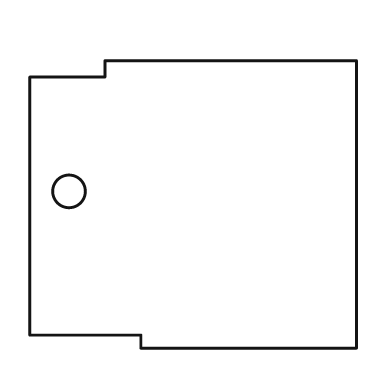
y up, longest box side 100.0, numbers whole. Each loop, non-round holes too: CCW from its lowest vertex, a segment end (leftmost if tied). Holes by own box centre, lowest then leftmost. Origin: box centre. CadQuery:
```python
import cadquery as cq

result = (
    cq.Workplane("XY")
    .moveTo(-16.0, -44.0)
    .lineTo(50.0, -44.0)
    .lineTo(50.0, 44.0)
    .lineTo(-27.0, 44.0)
    .lineTo(-27.0, 39.0)
    .lineTo(-50.0, 39.0)
    .lineTo(-50.0, -40.0)
    .lineTo(-16.0, -40.0)
    .close()
    .moveTo(-38.0, 4.0)
    .circle(5.0)
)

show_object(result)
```